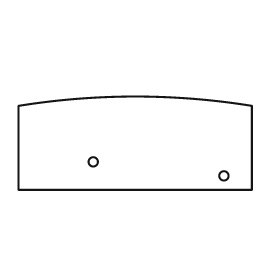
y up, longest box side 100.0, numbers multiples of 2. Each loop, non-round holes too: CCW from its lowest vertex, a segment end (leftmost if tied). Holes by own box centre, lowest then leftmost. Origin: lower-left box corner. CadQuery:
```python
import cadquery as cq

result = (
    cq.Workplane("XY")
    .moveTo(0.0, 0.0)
    .lineTo(100.0, 0.0)
    .lineTo(100.0, 36.0)
    .threePointArc((50.0, 40.0), (0.0, 36.0))
    .close()
    .moveTo(88.0, 6.0)
    .circle(2.0)
    .moveTo(32.0, 12.0)
    .circle(2.0)
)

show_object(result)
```